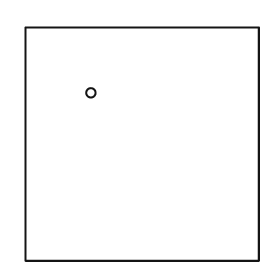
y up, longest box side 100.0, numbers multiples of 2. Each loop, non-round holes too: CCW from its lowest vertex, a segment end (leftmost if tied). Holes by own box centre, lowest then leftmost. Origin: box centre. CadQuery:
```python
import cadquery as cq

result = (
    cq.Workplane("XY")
    .moveTo(-50.0, -50.0)
    .lineTo(50.0, -50.0)
    .lineTo(50.0, 50.0)
    .lineTo(-50.0, 50.0)
    .close()
    .moveTo(-22.0, 22.0)
    .circle(2.0)
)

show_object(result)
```